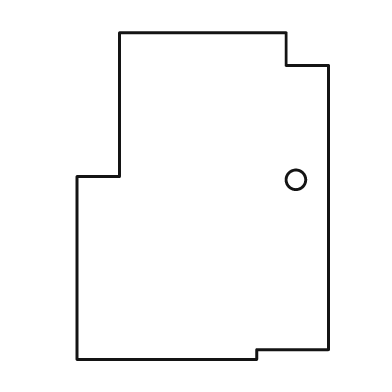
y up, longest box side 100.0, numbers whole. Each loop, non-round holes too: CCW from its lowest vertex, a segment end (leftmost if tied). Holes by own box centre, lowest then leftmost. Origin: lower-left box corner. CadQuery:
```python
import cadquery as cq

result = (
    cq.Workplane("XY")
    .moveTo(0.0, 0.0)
    .lineTo(55.0, 0.0)
    .lineTo(55.0, 3.0)
    .lineTo(77.0, 3.0)
    .lineTo(77.0, 90.0)
    .lineTo(64.0, 90.0)
    .lineTo(64.0, 100.0)
    .lineTo(13.0, 100.0)
    .lineTo(13.0, 56.0)
    .lineTo(0.0, 56.0)
    .close()
    .moveTo(67.0, 55.0)
    .circle(3.0)
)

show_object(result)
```